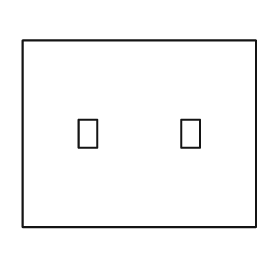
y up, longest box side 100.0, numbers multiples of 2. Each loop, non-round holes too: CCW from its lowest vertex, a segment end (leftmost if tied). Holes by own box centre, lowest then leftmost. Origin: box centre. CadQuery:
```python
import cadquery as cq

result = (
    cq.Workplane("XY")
    .moveTo(-50.0, -40.0)
    .lineTo(50.0, -40.0)
    .lineTo(50.0, 40.0)
    .lineTo(-50.0, 40.0)
    .close()
    .moveTo(-26.0, -6.0)
    .lineTo(-18.0, -6.0)
    .lineTo(-18.0, 6.0)
    .lineTo(-26.0, 6.0)
    .close()
    .moveTo(18.0, -6.0)
    .lineTo(26.0, -6.0)
    .lineTo(26.0, 6.0)
    .lineTo(18.0, 6.0)
    .close()
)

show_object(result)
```